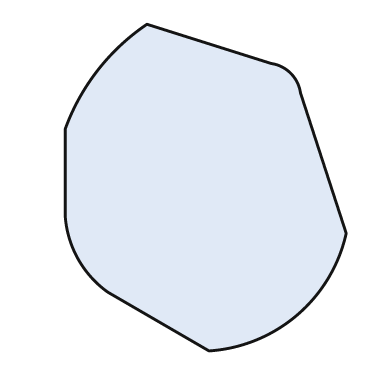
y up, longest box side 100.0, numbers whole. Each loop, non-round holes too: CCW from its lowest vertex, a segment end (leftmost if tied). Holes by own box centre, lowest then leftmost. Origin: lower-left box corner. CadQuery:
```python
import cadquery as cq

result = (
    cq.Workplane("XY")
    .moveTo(44.0, 0.0)
    .threePointArc((71.0, 11.0), (86.0, 36.0))
    .lineTo(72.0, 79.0)
    .threePointArc((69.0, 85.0), (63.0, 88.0))
    .lineTo(25.0, 100.0)
    .threePointArc((10.0, 86.0), (0.0, 68.0))
    .lineTo(0.0, 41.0)
    .threePointArc((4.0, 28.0), (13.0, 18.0))
    .close()
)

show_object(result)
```